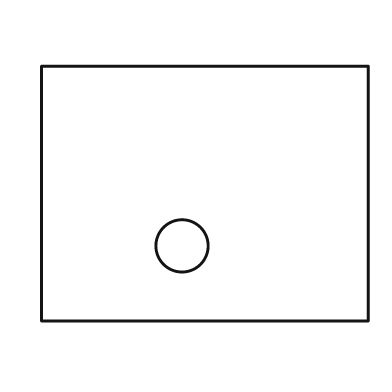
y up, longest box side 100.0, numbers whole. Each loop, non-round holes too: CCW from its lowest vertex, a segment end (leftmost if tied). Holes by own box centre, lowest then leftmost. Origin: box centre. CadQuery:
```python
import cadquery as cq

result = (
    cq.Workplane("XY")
    .moveTo(-50.0, -39.0)
    .lineTo(50.0, -39.0)
    .lineTo(50.0, 39.0)
    .lineTo(-50.0, 39.0)
    .close()
    .moveTo(-7.0, -16.0)
    .circle(8.0)
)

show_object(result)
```